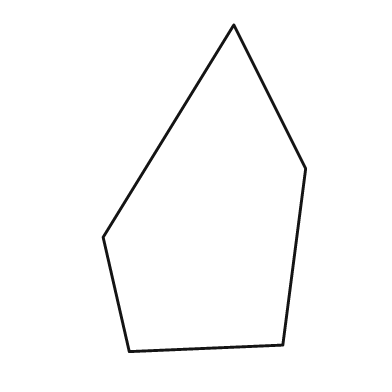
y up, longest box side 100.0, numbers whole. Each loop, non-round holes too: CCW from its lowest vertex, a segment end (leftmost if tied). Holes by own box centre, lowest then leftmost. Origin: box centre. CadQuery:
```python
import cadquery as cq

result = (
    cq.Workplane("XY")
    .moveTo(-23.0, -50.0)
    .lineTo(24.0, -48.0)
    .lineTo(31.0, 6.0)
    .lineTo(9.0, 50.0)
    .lineTo(-31.0, -15.0)
    .close()
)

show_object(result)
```